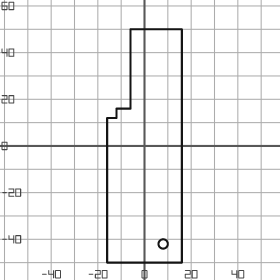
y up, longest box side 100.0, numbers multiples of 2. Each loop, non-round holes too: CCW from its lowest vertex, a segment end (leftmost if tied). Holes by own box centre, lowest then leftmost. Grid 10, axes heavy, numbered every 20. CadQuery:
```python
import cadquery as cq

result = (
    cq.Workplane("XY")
    .moveTo(-16.0, -50.0)
    .lineTo(16.0, -50.0)
    .lineTo(16.0, 50.0)
    .lineTo(-6.0, 50.0)
    .lineTo(-6.0, 16.0)
    .lineTo(-12.0, 16.0)
    .lineTo(-12.0, 12.0)
    .lineTo(-16.0, 12.0)
    .close()
    .moveTo(8.0, -42.0)
    .circle(2.0)
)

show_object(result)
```